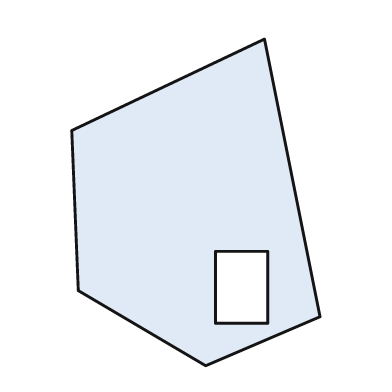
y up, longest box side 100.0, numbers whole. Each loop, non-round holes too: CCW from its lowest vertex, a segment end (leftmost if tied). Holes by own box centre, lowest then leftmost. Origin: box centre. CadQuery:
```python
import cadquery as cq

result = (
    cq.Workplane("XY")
    .moveTo(3.0, -50.0)
    .lineTo(38.0, -35.0)
    .lineTo(21.0, 50.0)
    .lineTo(-38.0, 22.0)
    .lineTo(-36.0, -27.0)
    .close()
    .moveTo(6.0, -37.0)
    .lineTo(22.0, -37.0)
    .lineTo(22.0, -15.0)
    .lineTo(6.0, -15.0)
    .close()
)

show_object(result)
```